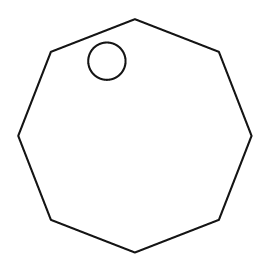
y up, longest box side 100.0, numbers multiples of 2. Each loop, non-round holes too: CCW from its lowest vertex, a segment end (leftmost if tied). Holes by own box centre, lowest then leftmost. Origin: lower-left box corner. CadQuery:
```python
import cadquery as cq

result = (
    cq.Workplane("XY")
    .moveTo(50.0, 0.0)
    .lineTo(86.0, 14.0)
    .lineTo(100.0, 50.0)
    .lineTo(86.0, 86.0)
    .lineTo(50.0, 100.0)
    .lineTo(14.0, 86.0)
    .lineTo(0.0, 50.0)
    .lineTo(14.0, 14.0)
    .close()
    .moveTo(38.0, 82.0)
    .circle(8.0)
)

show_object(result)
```